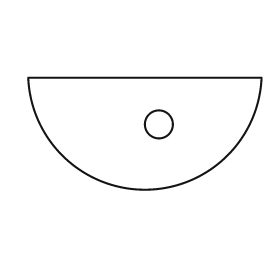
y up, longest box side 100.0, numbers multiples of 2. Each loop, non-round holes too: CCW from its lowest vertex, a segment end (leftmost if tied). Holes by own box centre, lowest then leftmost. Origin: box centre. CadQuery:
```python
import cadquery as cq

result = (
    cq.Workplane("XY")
    .moveTo(-50.0, 24.0)
    .threePointArc((0.0, -24.0), (50.0, 24.0))
    .close()
    .moveTo(6.0, 4.0)
    .circle(6.0)
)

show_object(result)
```